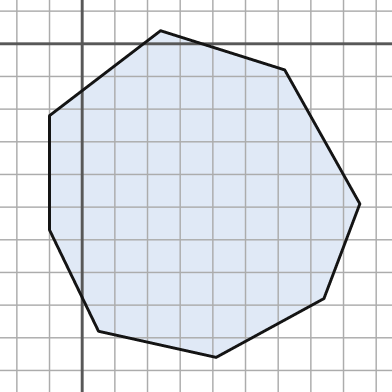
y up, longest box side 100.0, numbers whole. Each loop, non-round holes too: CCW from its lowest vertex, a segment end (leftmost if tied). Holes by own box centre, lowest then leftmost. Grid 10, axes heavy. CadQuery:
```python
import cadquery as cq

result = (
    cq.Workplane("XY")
    .moveTo(41.0, -96.0)
    .lineTo(74.0, -78.0)
    .lineTo(85.0, -49.0)
    .lineTo(62.0, -8.0)
    .lineTo(24.0, 4.0)
    .lineTo(-10.0, -22.0)
    .lineTo(-10.0, -57.0)
    .lineTo(5.0, -88.0)
    .close()
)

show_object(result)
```